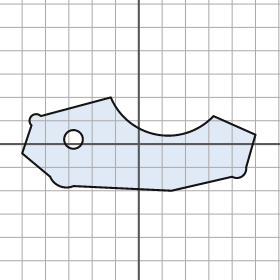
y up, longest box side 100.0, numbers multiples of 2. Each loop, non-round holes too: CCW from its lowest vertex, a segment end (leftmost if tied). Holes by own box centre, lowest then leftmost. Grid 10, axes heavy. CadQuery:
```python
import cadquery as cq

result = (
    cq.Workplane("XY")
    .moveTo(14.0, -20.0)
    .lineTo(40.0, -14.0)
    .threePointArc((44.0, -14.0), (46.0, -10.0))
    .lineTo(50.0, 4.0)
    .lineTo(32.0, 12.0)
    .threePointArc((8.0, 4.0), (-12.0, 20.0))
    .lineTo(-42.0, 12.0)
    .threePointArc((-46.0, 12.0), (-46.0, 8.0))
    .lineTo(-50.0, -4.0)
    .lineTo(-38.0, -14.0)
    .threePointArc((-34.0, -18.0), (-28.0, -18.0))
    .close()
    .moveTo(-28.0, 2.0)
    .circle(4.0)
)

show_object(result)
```